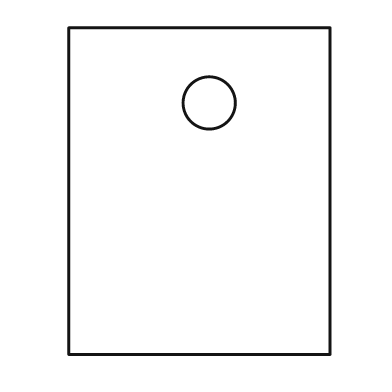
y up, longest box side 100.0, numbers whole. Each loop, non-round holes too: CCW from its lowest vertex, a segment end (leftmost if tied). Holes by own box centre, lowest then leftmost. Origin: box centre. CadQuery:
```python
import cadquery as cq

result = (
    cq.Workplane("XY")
    .moveTo(-40.0, -50.0)
    .lineTo(40.0, -50.0)
    .lineTo(40.0, 50.0)
    .lineTo(-40.0, 50.0)
    .close()
    .moveTo(3.0, 27.0)
    .circle(8.0)
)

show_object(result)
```